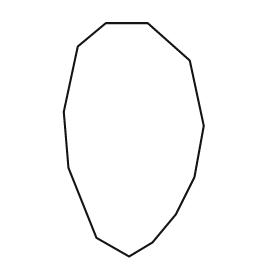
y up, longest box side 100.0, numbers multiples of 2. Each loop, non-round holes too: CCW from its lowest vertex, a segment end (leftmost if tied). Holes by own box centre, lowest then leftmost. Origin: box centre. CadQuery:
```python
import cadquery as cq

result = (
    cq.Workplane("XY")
    .moveTo(-2.0, -50.0)
    .lineTo(8.0, -44.0)
    .lineTo(18.0, -32.0)
    .lineTo(26.0, -16.0)
    .lineTo(30.0, 6.0)
    .lineTo(24.0, 34.0)
    .lineTo(6.0, 50.0)
    .lineTo(-12.0, 50.0)
    .lineTo(-24.0, 40.0)
    .lineTo(-30.0, 12.0)
    .lineTo(-28.0, -12.0)
    .lineTo(-16.0, -42.0)
    .close()
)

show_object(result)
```